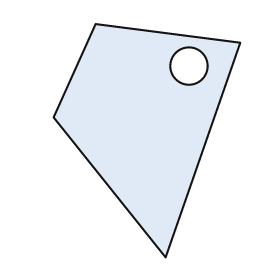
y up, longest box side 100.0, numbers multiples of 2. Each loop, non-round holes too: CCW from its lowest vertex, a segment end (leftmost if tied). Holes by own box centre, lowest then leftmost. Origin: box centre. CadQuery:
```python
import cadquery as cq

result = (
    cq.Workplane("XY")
    .moveTo(8.0, -50.0)
    .lineTo(40.0, 42.0)
    .lineTo(-22.0, 50.0)
    .lineTo(-40.0, 10.0)
    .close()
    .moveTo(18.0, 32.0)
    .circle(8.0)
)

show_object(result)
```